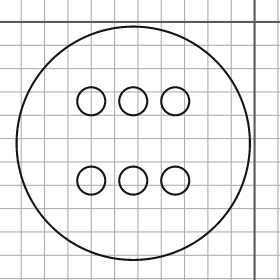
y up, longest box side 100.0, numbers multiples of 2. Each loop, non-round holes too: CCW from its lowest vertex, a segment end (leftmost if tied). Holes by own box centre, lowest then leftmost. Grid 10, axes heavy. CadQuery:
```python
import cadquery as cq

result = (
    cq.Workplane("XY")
    .moveTo(-52.0, -52.0)
    .circle(50.0)
    .moveTo(-70.0, -68.0)
    .circle(6.0)
    .moveTo(-52.0, -68.0)
    .circle(6.0)
    .moveTo(-34.0, -68.0)
    .circle(6.0)
    .moveTo(-70.0, -34.0)
    .circle(6.0)
    .moveTo(-52.0, -34.0)
    .circle(6.0)
    .moveTo(-34.0, -34.0)
    .circle(6.0)
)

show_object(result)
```